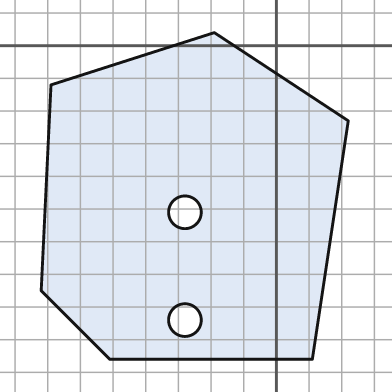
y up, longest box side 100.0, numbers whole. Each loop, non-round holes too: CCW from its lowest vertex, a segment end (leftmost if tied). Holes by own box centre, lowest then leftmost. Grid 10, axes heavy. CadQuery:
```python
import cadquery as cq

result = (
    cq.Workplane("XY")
    .moveTo(-51.0, -96.0)
    .lineTo(11.0, -96.0)
    .lineTo(22.0, -23.0)
    .lineTo(-19.0, 4.0)
    .lineTo(-69.0, -12.0)
    .lineTo(-72.0, -75.0)
    .close()
    .moveTo(-28.0, -84.0)
    .circle(5.0)
    .moveTo(-28.0, -51.0)
    .circle(5.0)
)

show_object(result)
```